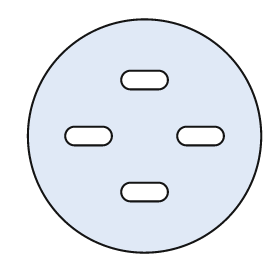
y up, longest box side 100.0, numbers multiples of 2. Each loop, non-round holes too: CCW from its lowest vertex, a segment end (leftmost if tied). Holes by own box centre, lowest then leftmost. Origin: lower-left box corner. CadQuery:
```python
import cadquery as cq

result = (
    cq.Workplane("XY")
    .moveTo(50.0, 50.0)
    .circle(50.0)
    .moveTo(44.0, 22.0)
    .lineTo(56.0, 22.0)
    .threePointArc((60.0, 26.0), (56.0, 30.0))
    .lineTo(44.0, 30.0)
    .threePointArc((40.0, 26.0), (44.0, 22.0))
    .close()
    .moveTo(20.0, 46.0)
    .lineTo(32.0, 46.0)
    .threePointArc((36.0, 50.0), (32.0, 54.0))
    .lineTo(20.0, 54.0)
    .threePointArc((16.0, 50.0), (20.0, 46.0))
    .close()
    .moveTo(68.0, 46.0)
    .lineTo(80.0, 46.0)
    .threePointArc((84.0, 50.0), (80.0, 54.0))
    .lineTo(68.0, 54.0)
    .threePointArc((64.0, 50.0), (68.0, 46.0))
    .close()
    .moveTo(44.0, 70.0)
    .lineTo(56.0, 70.0)
    .threePointArc((60.0, 74.0), (56.0, 78.0))
    .lineTo(44.0, 78.0)
    .threePointArc((40.0, 74.0), (44.0, 70.0))
    .close()
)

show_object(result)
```